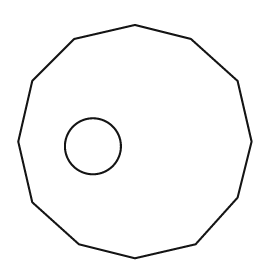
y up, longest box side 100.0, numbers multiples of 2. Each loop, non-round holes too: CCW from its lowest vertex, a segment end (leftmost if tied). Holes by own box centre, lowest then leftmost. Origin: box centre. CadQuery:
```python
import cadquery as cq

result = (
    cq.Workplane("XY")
    .moveTo(0.0, -50.0)
    .lineTo(26.0, -44.0)
    .lineTo(44.0, -24.0)
    .lineTo(50.0, 0.0)
    .lineTo(44.0, 26.0)
    .lineTo(24.0, 44.0)
    .lineTo(0.0, 50.0)
    .lineTo(-26.0, 44.0)
    .lineTo(-44.0, 26.0)
    .lineTo(-50.0, 0.0)
    .lineTo(-44.0, -26.0)
    .lineTo(-24.0, -44.0)
    .close()
    .moveTo(-18.0, -2.0)
    .circle(12.0)
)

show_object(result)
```